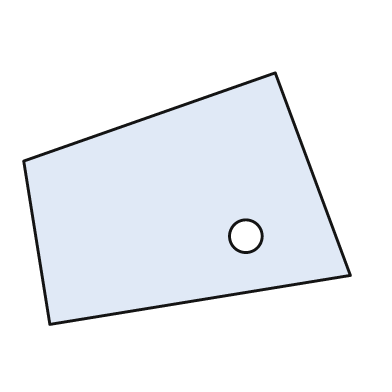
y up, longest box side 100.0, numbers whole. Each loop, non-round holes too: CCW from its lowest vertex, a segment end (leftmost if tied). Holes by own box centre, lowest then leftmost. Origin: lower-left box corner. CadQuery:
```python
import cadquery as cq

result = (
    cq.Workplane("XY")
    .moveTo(8.0, 0.0)
    .lineTo(100.0, 15.0)
    .lineTo(77.0, 77.0)
    .lineTo(0.0, 50.0)
    .close()
    .moveTo(68.0, 27.0)
    .circle(5.0)
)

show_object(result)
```